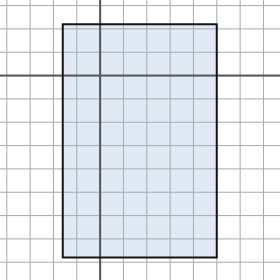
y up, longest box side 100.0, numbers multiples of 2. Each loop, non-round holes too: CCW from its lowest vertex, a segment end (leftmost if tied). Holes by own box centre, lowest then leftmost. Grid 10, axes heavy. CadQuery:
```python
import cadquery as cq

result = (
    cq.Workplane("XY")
    .moveTo(-16.0, -78.0)
    .lineTo(50.0, -78.0)
    .lineTo(50.0, 22.0)
    .lineTo(-16.0, 22.0)
    .close()
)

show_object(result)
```